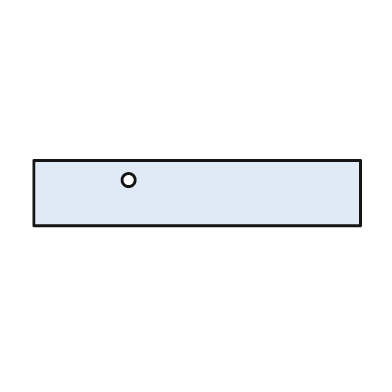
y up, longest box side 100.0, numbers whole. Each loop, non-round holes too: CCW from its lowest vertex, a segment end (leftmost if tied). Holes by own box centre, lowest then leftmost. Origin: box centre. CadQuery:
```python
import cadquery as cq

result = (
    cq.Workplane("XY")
    .moveTo(-50.0, -10.0)
    .lineTo(50.0, -10.0)
    .lineTo(50.0, 10.0)
    .lineTo(-50.0, 10.0)
    .close()
    .moveTo(-21.0, 4.0)
    .circle(2.0)
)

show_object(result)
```